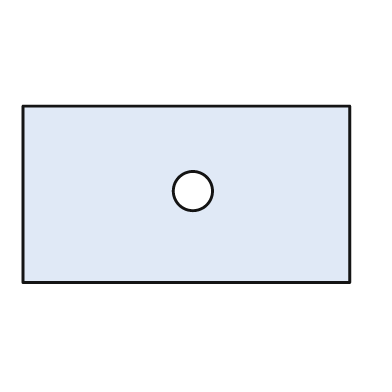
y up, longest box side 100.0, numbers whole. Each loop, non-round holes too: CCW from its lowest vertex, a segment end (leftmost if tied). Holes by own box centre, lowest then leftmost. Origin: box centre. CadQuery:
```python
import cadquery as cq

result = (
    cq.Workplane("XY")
    .moveTo(-50.0, -27.0)
    .lineTo(50.0, -27.0)
    .lineTo(50.0, 27.0)
    .lineTo(-50.0, 27.0)
    .close()
    .moveTo(2.0, 1.0)
    .circle(6.0)
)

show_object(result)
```